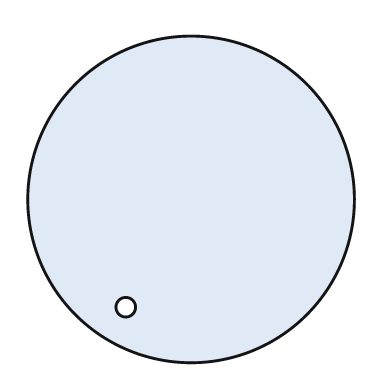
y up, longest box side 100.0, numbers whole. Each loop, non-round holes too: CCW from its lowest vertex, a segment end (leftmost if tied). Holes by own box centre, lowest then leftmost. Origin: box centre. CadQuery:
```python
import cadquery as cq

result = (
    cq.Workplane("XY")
    .moveTo(0.0, 0.0)
    .circle(50.0)
    .moveTo(-20.0, -33.0)
    .circle(3.0)
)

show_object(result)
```